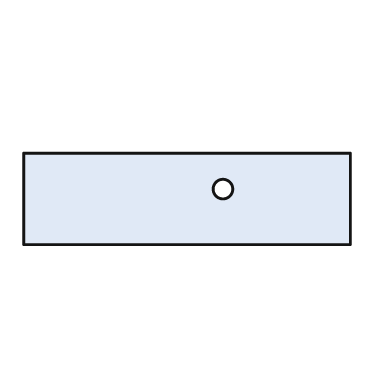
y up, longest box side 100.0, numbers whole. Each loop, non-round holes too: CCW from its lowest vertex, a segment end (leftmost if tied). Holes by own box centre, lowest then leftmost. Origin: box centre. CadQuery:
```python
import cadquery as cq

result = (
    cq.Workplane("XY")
    .moveTo(-50.0, -14.0)
    .lineTo(50.0, -14.0)
    .lineTo(50.0, 14.0)
    .lineTo(-50.0, 14.0)
    .close()
    .moveTo(11.0, 3.0)
    .circle(3.0)
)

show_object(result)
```